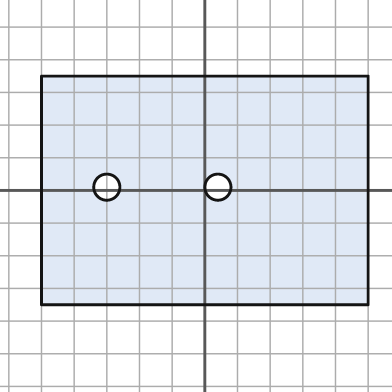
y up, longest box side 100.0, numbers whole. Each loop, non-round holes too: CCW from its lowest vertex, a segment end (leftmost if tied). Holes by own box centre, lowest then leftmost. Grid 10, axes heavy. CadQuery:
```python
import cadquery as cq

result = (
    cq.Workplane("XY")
    .moveTo(-50.0, -35.0)
    .lineTo(50.0, -35.0)
    .lineTo(50.0, 35.0)
    .lineTo(-50.0, 35.0)
    .close()
    .moveTo(-30.0, 1.0)
    .circle(4.0)
    .moveTo(4.0, 1.0)
    .circle(4.0)
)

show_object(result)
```